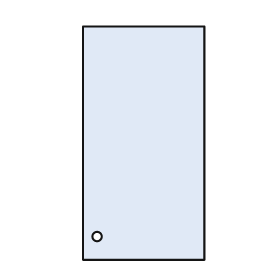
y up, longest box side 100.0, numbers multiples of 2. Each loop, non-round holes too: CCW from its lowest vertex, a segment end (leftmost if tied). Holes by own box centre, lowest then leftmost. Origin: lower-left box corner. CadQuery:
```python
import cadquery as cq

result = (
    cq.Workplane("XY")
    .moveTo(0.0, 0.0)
    .lineTo(52.0, 0.0)
    .lineTo(52.0, 100.0)
    .lineTo(0.0, 100.0)
    .close()
    .moveTo(6.0, 10.0)
    .circle(2.0)
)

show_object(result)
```